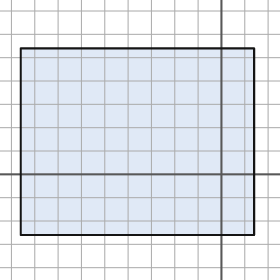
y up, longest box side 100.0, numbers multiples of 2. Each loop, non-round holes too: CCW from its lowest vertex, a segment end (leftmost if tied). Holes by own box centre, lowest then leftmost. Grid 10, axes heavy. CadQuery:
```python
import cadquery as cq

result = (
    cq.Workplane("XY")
    .moveTo(-86.0, -26.0)
    .lineTo(14.0, -26.0)
    .lineTo(14.0, 54.0)
    .lineTo(-86.0, 54.0)
    .close()
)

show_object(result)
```